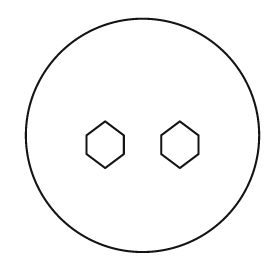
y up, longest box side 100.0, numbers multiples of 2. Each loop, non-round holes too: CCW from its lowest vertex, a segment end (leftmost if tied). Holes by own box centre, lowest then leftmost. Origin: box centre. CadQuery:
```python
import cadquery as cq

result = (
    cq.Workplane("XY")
    .moveTo(0.0, 0.0)
    .circle(50.0)
    .moveTo(-16.0, -14.0)
    .lineTo(-8.0, -8.0)
    .lineTo(-8.0, 0.0)
    .lineTo(-16.0, 6.0)
    .lineTo(-24.0, 0.0)
    .lineTo(-24.0, -8.0)
    .close()
    .moveTo(16.0, -14.0)
    .lineTo(24.0, -8.0)
    .lineTo(24.0, 0.0)
    .lineTo(16.0, 6.0)
    .lineTo(8.0, 0.0)
    .lineTo(8.0, -8.0)
    .close()
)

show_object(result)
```